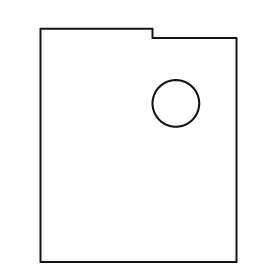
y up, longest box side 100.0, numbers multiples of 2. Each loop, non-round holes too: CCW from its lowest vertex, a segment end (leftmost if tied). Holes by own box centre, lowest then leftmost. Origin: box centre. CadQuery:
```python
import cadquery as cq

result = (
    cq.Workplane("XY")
    .moveTo(-42.0, -50.0)
    .lineTo(42.0, -50.0)
    .lineTo(42.0, 46.0)
    .lineTo(6.0, 46.0)
    .lineTo(6.0, 50.0)
    .lineTo(-42.0, 50.0)
    .close()
    .moveTo(16.0, 18.0)
    .circle(10.0)
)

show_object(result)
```